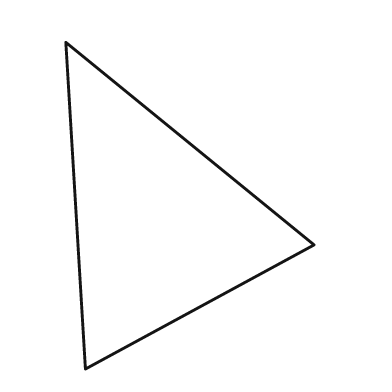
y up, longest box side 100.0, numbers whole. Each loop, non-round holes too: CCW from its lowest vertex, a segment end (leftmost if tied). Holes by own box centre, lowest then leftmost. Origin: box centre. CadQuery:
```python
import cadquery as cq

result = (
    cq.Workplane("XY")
    .moveTo(-32.0, -50.0)
    .lineTo(38.0, -12.0)
    .lineTo(-38.0, 50.0)
    .close()
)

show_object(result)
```